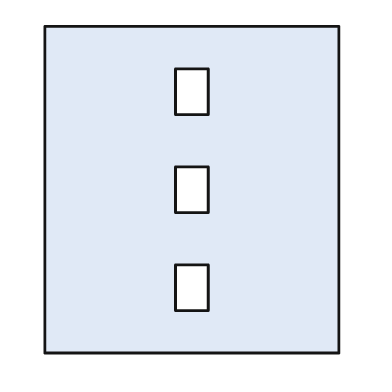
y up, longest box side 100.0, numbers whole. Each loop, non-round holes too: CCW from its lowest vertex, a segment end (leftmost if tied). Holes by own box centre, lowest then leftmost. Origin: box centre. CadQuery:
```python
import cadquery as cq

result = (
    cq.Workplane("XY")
    .moveTo(-45.0, -50.0)
    .lineTo(45.0, -50.0)
    .lineTo(45.0, 50.0)
    .lineTo(-45.0, 50.0)
    .close()
    .moveTo(-5.0, -37.0)
    .lineTo(5.0, -37.0)
    .lineTo(5.0, -23.0)
    .lineTo(-5.0, -23.0)
    .close()
    .moveTo(-5.0, -7.0)
    .lineTo(5.0, -7.0)
    .lineTo(5.0, 7.0)
    .lineTo(-5.0, 7.0)
    .close()
    .moveTo(-5.0, 23.0)
    .lineTo(5.0, 23.0)
    .lineTo(5.0, 37.0)
    .lineTo(-5.0, 37.0)
    .close()
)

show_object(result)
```